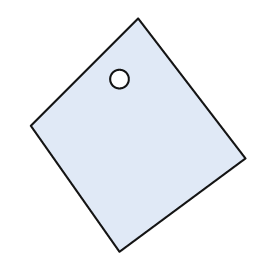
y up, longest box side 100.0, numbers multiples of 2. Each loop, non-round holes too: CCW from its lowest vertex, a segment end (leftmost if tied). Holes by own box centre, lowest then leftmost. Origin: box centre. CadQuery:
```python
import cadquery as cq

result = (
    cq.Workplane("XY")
    .moveTo(-8.0, -50.0)
    .lineTo(46.0, -10.0)
    .lineTo(0.0, 50.0)
    .lineTo(-46.0, 4.0)
    .close()
    .moveTo(-8.0, 24.0)
    .circle(4.0)
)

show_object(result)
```